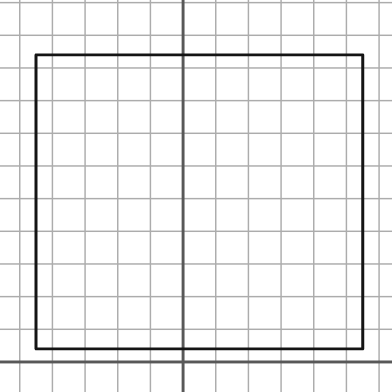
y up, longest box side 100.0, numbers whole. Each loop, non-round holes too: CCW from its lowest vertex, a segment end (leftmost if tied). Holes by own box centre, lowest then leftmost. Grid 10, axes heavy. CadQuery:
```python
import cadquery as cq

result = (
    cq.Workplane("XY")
    .moveTo(-45.0, 4.0)
    .lineTo(55.0, 4.0)
    .lineTo(55.0, 94.0)
    .lineTo(-45.0, 94.0)
    .close()
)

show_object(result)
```